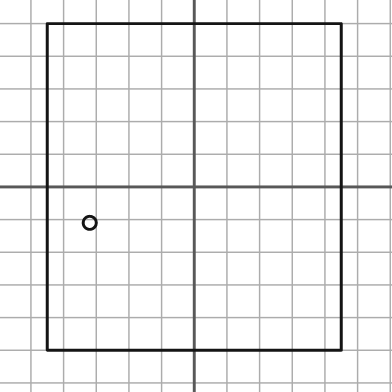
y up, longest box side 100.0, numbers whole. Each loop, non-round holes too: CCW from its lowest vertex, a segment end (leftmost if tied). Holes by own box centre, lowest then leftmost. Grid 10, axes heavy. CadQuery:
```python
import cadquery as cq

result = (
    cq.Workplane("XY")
    .moveTo(-45.0, -50.0)
    .lineTo(45.0, -50.0)
    .lineTo(45.0, 50.0)
    .lineTo(-45.0, 50.0)
    .close()
    .moveTo(-32.0, -11.0)
    .circle(2.0)
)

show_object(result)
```